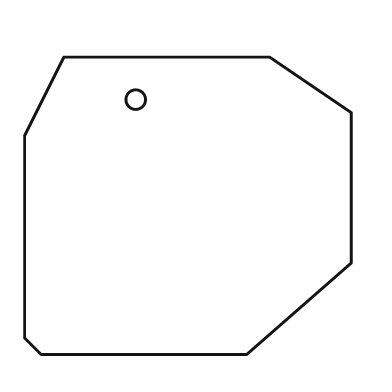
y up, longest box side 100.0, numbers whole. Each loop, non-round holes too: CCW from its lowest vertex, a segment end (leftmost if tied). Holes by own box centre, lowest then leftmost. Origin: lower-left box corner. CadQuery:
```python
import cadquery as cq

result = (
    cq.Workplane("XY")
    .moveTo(5.0, 0.0)
    .lineTo(68.0, 0.0)
    .lineTo(100.0, 28.0)
    .lineTo(100.0, 74.0)
    .lineTo(75.0, 91.0)
    .lineTo(12.0, 91.0)
    .lineTo(0.0, 67.0)
    .lineTo(0.0, 5.0)
    .close()
    .moveTo(34.0, 78.0)
    .circle(3.0)
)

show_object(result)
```